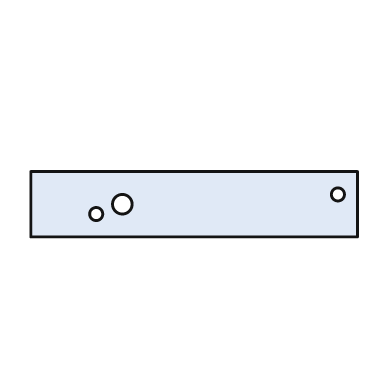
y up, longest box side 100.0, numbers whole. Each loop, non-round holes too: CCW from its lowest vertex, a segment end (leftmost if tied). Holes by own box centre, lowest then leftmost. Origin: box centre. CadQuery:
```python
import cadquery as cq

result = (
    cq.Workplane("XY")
    .moveTo(-50.0, -10.0)
    .lineTo(50.0, -10.0)
    .lineTo(50.0, 10.0)
    .lineTo(-50.0, 10.0)
    .close()
    .moveTo(-30.0, -3.0)
    .circle(2.0)
    .moveTo(-22.0, 0.0)
    .circle(3.0)
    .moveTo(44.0, 3.0)
    .circle(2.0)
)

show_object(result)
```